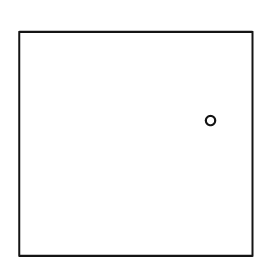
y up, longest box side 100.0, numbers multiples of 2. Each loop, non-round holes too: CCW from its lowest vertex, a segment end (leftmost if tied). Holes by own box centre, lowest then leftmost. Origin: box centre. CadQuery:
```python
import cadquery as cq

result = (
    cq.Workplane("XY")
    .moveTo(-50.0, -48.0)
    .lineTo(50.0, -48.0)
    .lineTo(50.0, 48.0)
    .lineTo(-50.0, 48.0)
    .close()
    .moveTo(32.0, 10.0)
    .circle(2.0)
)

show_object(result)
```